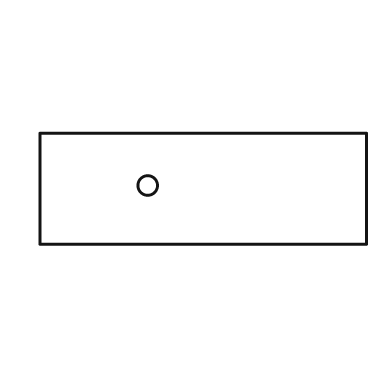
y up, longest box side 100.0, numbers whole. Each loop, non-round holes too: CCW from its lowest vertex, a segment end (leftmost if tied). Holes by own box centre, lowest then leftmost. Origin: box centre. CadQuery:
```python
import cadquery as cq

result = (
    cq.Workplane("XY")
    .moveTo(-50.0, -17.0)
    .lineTo(50.0, -17.0)
    .lineTo(50.0, 17.0)
    .lineTo(-50.0, 17.0)
    .close()
    .moveTo(-17.0, 1.0)
    .circle(3.0)
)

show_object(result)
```